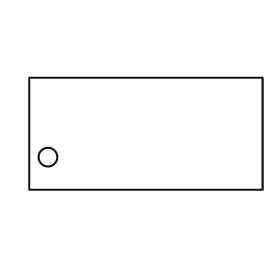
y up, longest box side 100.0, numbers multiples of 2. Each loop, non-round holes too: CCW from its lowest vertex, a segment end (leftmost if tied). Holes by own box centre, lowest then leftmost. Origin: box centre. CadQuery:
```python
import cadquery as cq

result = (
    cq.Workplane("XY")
    .moveTo(-50.0, -24.0)
    .lineTo(50.0, -24.0)
    .lineTo(50.0, 24.0)
    .lineTo(-50.0, 24.0)
    .close()
    .moveTo(-42.0, -10.0)
    .circle(4.0)
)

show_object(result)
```